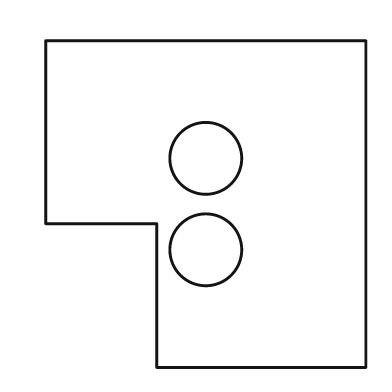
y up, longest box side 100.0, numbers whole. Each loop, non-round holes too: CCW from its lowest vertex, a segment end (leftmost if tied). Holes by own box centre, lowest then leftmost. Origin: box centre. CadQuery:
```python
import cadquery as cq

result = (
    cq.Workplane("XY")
    .moveTo(-15.0, -50.0)
    .lineTo(49.0, -50.0)
    .lineTo(49.0, 50.0)
    .lineTo(-49.0, 50.0)
    .lineTo(-49.0, -6.0)
    .lineTo(-15.0, -6.0)
    .close()
    .moveTo(0.0, -14.0)
    .circle(11.0)
    .moveTo(0.0, 14.0)
    .circle(11.0)
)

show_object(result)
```